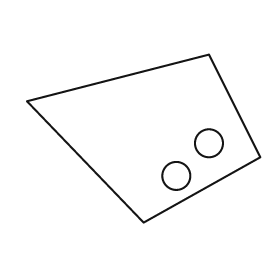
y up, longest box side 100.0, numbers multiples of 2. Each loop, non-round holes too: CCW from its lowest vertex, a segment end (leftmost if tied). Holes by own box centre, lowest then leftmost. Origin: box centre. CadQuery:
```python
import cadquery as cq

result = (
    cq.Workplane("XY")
    .moveTo(0.0, -36.0)
    .lineTo(50.0, -8.0)
    .lineTo(28.0, 36.0)
    .lineTo(-50.0, 16.0)
    .close()
    .moveTo(14.0, -16.0)
    .circle(6.0)
    .moveTo(28.0, -2.0)
    .circle(6.0)
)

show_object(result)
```